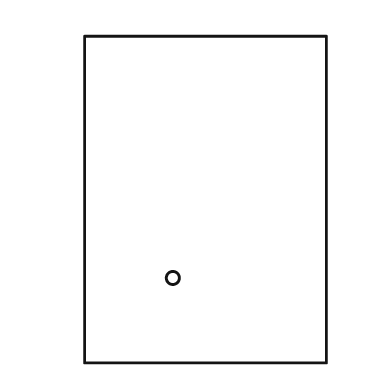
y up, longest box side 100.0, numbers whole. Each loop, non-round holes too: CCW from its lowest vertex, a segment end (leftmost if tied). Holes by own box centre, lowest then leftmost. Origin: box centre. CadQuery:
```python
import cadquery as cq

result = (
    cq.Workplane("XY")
    .moveTo(-37.0, -50.0)
    .lineTo(37.0, -50.0)
    .lineTo(37.0, 50.0)
    .lineTo(-37.0, 50.0)
    .close()
    .moveTo(-10.0, -24.0)
    .circle(2.0)
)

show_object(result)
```